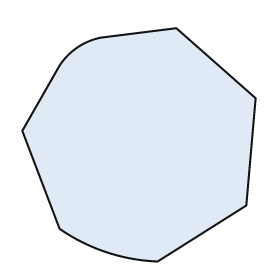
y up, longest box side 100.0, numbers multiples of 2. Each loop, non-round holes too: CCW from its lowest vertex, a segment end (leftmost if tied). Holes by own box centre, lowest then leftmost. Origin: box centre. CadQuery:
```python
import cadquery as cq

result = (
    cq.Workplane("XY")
    .moveTo(8.0, -50.0)
    .lineTo(46.0, -26.0)
    .lineTo(50.0, 20.0)
    .lineTo(16.0, 50.0)
    .lineTo(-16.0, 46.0)
    .threePointArc((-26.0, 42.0), (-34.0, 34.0))
    .lineTo(-50.0, 6.0)
    .lineTo(-34.0, -36.0)
    .threePointArc((-14.0, -46.0), (8.0, -50.0))
    .close()
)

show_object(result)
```